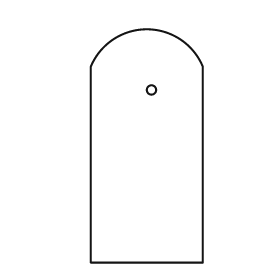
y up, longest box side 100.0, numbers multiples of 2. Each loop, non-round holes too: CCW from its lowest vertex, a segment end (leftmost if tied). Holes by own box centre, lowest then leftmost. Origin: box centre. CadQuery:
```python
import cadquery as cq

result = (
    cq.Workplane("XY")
    .moveTo(-24.0, -50.0)
    .lineTo(24.0, -50.0)
    .lineTo(24.0, 34.0)
    .threePointArc((0.0, 50.0), (-24.0, 34.0))
    .close()
    .moveTo(2.0, 24.0)
    .circle(2.0)
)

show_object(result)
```